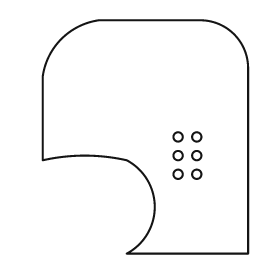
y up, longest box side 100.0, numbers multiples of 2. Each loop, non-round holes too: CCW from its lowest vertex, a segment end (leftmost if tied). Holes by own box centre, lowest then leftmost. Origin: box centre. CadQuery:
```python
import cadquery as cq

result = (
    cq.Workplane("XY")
    .moveTo(-8.0, -50.0)
    .lineTo(44.0, -50.0)
    .lineTo(44.0, 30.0)
    .threePointArc((38.0, 44.0), (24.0, 50.0))
    .lineTo(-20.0, 50.0)
    .threePointArc((-36.0, 42.0), (-44.0, 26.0))
    .lineTo(-44.0, -10.0)
    .threePointArc((-26.0, -8.0), (-8.0, -10.0))
    .threePointArc((4.0, -30.0), (-8.0, -50.0))
    .close()
    .moveTo(14.0, -16.0)
    .circle(2.0)
    .moveTo(22.0, -16.0)
    .circle(2.0)
    .moveTo(14.0, -8.0)
    .circle(2.0)
    .moveTo(22.0, -8.0)
    .circle(2.0)
    .moveTo(14.0, 0.0)
    .circle(2.0)
    .moveTo(22.0, 0.0)
    .circle(2.0)
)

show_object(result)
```